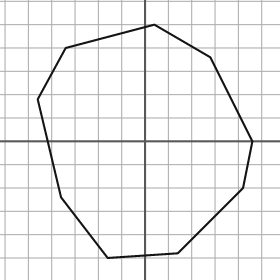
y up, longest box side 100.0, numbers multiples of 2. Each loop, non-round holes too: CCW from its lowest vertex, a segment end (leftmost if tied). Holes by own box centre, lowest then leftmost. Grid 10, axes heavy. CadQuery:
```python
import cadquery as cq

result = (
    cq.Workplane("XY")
    .moveTo(-16.0, -50.0)
    .lineTo(14.0, -48.0)
    .lineTo(42.0, -20.0)
    .lineTo(46.0, 0.0)
    .lineTo(28.0, 36.0)
    .lineTo(4.0, 50.0)
    .lineTo(-34.0, 40.0)
    .lineTo(-46.0, 18.0)
    .lineTo(-36.0, -24.0)
    .close()
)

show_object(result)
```